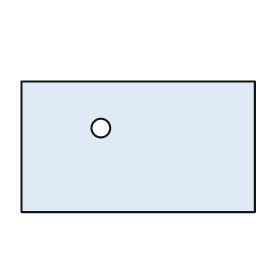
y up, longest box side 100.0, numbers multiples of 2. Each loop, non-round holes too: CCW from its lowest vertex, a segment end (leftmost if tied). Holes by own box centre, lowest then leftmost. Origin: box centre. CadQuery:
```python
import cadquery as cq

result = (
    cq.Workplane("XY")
    .moveTo(-50.0, -28.0)
    .lineTo(50.0, -28.0)
    .lineTo(50.0, 28.0)
    .lineTo(-50.0, 28.0)
    .close()
    .moveTo(-16.0, 8.0)
    .circle(4.0)
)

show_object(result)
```